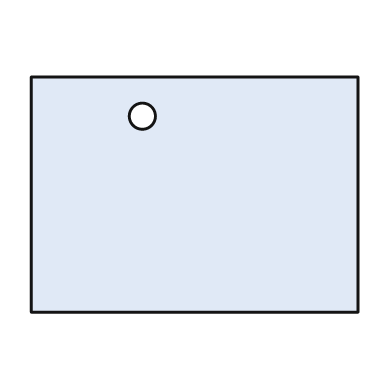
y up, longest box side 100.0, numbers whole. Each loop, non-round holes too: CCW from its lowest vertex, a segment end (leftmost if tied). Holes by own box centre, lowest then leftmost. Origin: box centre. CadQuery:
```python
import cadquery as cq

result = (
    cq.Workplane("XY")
    .moveTo(-50.0, -36.0)
    .lineTo(50.0, -36.0)
    .lineTo(50.0, 36.0)
    .lineTo(-50.0, 36.0)
    .close()
    .moveTo(-16.0, 24.0)
    .circle(4.0)
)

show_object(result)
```